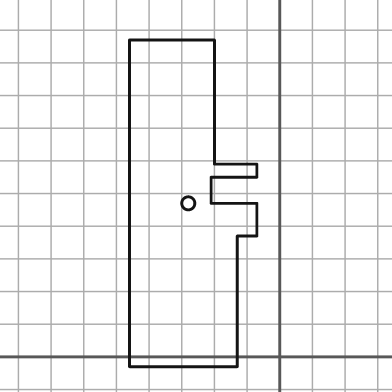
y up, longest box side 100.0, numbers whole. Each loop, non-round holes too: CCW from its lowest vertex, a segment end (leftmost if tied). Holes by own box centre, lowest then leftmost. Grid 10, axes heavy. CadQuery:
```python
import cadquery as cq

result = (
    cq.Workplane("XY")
    .moveTo(-46.0, -3.0)
    .lineTo(-13.0, -3.0)
    .lineTo(-13.0, 37.0)
    .lineTo(-7.0, 37.0)
    .lineTo(-7.0, 47.0)
    .lineTo(-21.0, 47.0)
    .lineTo(-21.0, 55.0)
    .lineTo(-7.0, 55.0)
    .lineTo(-7.0, 59.0)
    .lineTo(-20.0, 59.0)
    .lineTo(-20.0, 97.0)
    .lineTo(-46.0, 97.0)
    .close()
    .moveTo(-28.0, 47.0)
    .circle(2.0)
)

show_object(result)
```